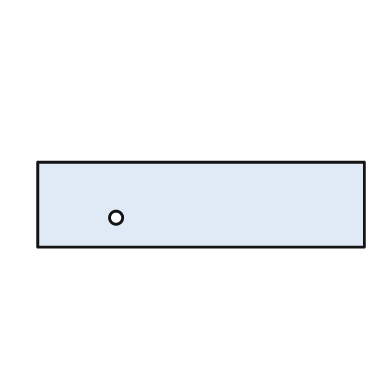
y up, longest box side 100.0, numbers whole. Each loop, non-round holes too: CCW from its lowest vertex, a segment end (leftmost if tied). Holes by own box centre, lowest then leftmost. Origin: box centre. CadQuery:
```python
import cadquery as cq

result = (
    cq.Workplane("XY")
    .moveTo(-50.0, -13.0)
    .lineTo(50.0, -13.0)
    .lineTo(50.0, 13.0)
    .lineTo(-50.0, 13.0)
    .close()
    .moveTo(-26.0, -4.0)
    .circle(2.0)
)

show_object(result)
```